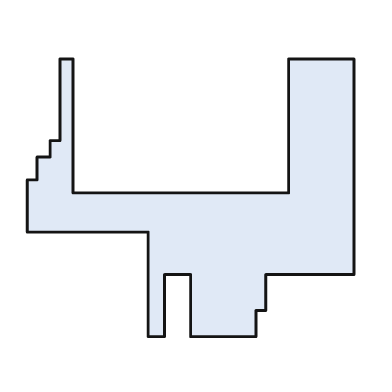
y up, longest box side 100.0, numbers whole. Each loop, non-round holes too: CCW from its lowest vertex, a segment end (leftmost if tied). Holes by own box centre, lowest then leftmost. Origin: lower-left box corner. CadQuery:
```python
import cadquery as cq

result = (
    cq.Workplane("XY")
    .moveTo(37.0, 0.0)
    .lineTo(42.0, 0.0)
    .lineTo(42.0, 19.0)
    .lineTo(50.0, 19.0)
    .lineTo(50.0, 0.0)
    .lineTo(70.0, 0.0)
    .lineTo(70.0, 8.0)
    .lineTo(73.0, 8.0)
    .lineTo(73.0, 19.0)
    .lineTo(100.0, 19.0)
    .lineTo(100.0, 85.0)
    .lineTo(80.0, 85.0)
    .lineTo(80.0, 44.0)
    .lineTo(14.0, 44.0)
    .lineTo(14.0, 85.0)
    .lineTo(10.0, 85.0)
    .lineTo(10.0, 60.0)
    .lineTo(7.0, 60.0)
    .lineTo(7.0, 55.0)
    .lineTo(3.0, 55.0)
    .lineTo(3.0, 48.0)
    .lineTo(0.0, 48.0)
    .lineTo(0.0, 32.0)
    .lineTo(37.0, 32.0)
    .close()
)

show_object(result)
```